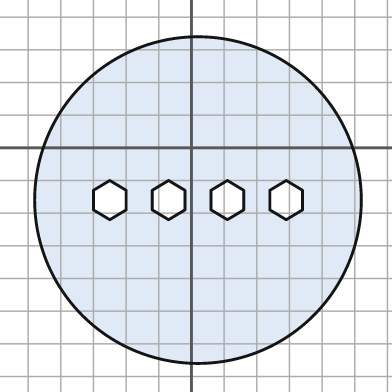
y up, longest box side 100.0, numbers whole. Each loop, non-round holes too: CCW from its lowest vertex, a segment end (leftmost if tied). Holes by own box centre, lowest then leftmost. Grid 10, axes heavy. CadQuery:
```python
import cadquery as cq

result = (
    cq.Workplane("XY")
    .moveTo(2.0, -16.0)
    .circle(50.0)
    .moveTo(-25.0, -22.0)
    .lineTo(-20.0, -19.0)
    .lineTo(-20.0, -13.0)
    .lineTo(-25.0, -10.0)
    .lineTo(-30.0, -13.0)
    .lineTo(-30.0, -19.0)
    .close()
    .moveTo(-7.0, -22.0)
    .lineTo(-2.0, -19.0)
    .lineTo(-2.0, -13.0)
    .lineTo(-7.0, -10.0)
    .lineTo(-12.0, -13.0)
    .lineTo(-12.0, -19.0)
    .close()
    .moveTo(11.0, -22.0)
    .lineTo(16.0, -19.0)
    .lineTo(16.0, -13.0)
    .lineTo(11.0, -10.0)
    .lineTo(6.0, -13.0)
    .lineTo(6.0, -19.0)
    .close()
    .moveTo(29.0, -22.0)
    .lineTo(34.0, -19.0)
    .lineTo(34.0, -13.0)
    .lineTo(29.0, -10.0)
    .lineTo(24.0, -13.0)
    .lineTo(24.0, -19.0)
    .close()
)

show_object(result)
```